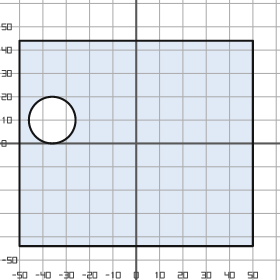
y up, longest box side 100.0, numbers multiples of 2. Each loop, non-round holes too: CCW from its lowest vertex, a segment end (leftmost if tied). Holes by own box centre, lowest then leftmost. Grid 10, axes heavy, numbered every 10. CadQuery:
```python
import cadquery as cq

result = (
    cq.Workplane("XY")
    .moveTo(-50.0, -44.0)
    .lineTo(50.0, -44.0)
    .lineTo(50.0, 44.0)
    .lineTo(-50.0, 44.0)
    .close()
    .moveTo(-36.0, 10.0)
    .circle(10.0)
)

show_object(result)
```